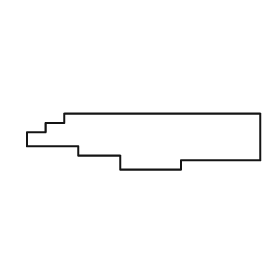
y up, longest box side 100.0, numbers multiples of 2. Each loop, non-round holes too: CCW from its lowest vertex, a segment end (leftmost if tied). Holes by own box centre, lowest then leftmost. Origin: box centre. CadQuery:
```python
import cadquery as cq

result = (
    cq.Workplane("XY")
    .moveTo(-10.0, -12.0)
    .lineTo(16.0, -12.0)
    .lineTo(16.0, -8.0)
    .lineTo(50.0, -8.0)
    .lineTo(50.0, 12.0)
    .lineTo(-34.0, 12.0)
    .lineTo(-34.0, 8.0)
    .lineTo(-42.0, 8.0)
    .lineTo(-42.0, 4.0)
    .lineTo(-50.0, 4.0)
    .lineTo(-50.0, -2.0)
    .lineTo(-28.0, -2.0)
    .lineTo(-28.0, -6.0)
    .lineTo(-10.0, -6.0)
    .close()
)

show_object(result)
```